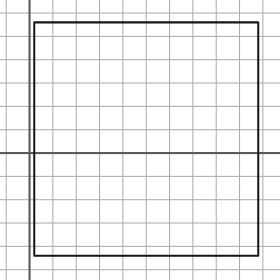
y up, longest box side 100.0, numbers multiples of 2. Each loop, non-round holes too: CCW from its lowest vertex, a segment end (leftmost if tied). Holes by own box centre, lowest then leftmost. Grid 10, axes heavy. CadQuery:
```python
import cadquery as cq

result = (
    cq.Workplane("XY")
    .moveTo(2.0, -44.0)
    .lineTo(98.0, -44.0)
    .lineTo(98.0, 56.0)
    .lineTo(2.0, 56.0)
    .close()
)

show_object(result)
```